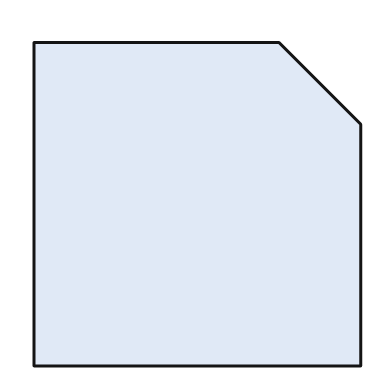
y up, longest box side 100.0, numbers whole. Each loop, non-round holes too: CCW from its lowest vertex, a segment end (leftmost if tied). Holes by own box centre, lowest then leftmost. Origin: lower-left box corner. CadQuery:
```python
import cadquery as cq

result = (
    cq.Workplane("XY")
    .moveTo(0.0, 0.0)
    .lineTo(100.0, 0.0)
    .lineTo(100.0, 74.0)
    .lineTo(75.0, 99.0)
    .lineTo(0.0, 99.0)
    .close()
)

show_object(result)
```